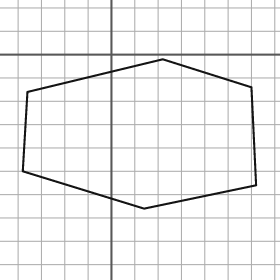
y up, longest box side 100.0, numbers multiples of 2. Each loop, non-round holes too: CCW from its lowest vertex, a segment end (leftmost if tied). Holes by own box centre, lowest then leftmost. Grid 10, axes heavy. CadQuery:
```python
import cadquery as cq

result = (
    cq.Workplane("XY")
    .moveTo(14.0, -66.0)
    .lineTo(62.0, -56.0)
    .lineTo(60.0, -14.0)
    .lineTo(22.0, -2.0)
    .lineTo(-36.0, -16.0)
    .lineTo(-38.0, -50.0)
    .close()
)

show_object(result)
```